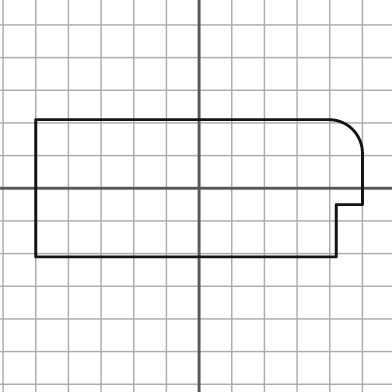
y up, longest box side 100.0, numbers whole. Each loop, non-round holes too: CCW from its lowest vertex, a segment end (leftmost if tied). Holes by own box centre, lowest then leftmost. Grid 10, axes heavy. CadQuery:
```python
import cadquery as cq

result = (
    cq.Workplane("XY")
    .moveTo(-50.0, -21.0)
    .lineTo(42.0, -21.0)
    .lineTo(42.0, -5.0)
    .lineTo(50.0, -5.0)
    .lineTo(50.0, 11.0)
    .threePointArc((47.0, 18.0), (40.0, 21.0))
    .lineTo(-50.0, 21.0)
    .close()
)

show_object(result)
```